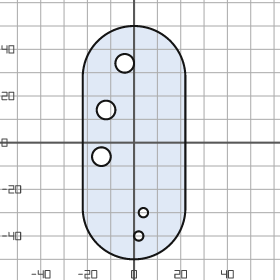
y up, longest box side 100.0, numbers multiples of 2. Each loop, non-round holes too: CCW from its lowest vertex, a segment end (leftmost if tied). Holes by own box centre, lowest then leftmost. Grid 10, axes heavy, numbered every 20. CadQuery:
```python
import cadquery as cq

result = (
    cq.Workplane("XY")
    .moveTo(-22.0, -28.0)
    .threePointArc((0.0, -50.0), (22.0, -28.0))
    .lineTo(22.0, 28.0)
    .threePointArc((0.0, 50.0), (-22.0, 28.0))
    .close()
    .moveTo(2.0, -40.0)
    .circle(2.0)
    .moveTo(4.0, -30.0)
    .circle(2.0)
    .moveTo(-14.0, -6.0)
    .circle(4.0)
    .moveTo(-12.0, 14.0)
    .circle(4.0)
    .moveTo(-4.0, 34.0)
    .circle(4.0)
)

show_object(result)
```